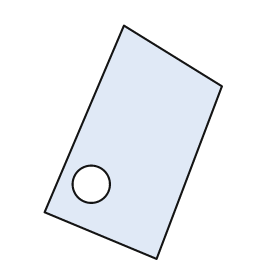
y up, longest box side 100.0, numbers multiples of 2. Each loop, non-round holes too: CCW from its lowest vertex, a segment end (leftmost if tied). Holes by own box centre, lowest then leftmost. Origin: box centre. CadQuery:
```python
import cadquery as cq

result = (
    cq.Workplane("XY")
    .moveTo(10.0, -50.0)
    .lineTo(38.0, 24.0)
    .lineTo(-4.0, 50.0)
    .lineTo(-38.0, -30.0)
    .close()
    .moveTo(-18.0, -18.0)
    .circle(8.0)
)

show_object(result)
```